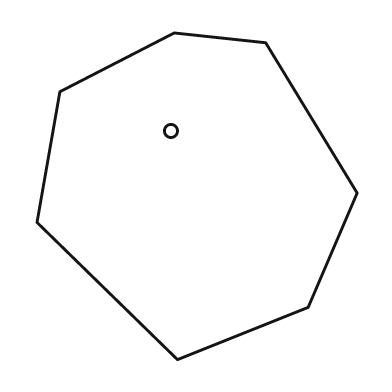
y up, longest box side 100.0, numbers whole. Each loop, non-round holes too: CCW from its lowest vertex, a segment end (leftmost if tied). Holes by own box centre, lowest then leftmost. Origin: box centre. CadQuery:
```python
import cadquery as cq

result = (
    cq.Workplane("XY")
    .moveTo(-6.0, -50.0)
    .lineTo(34.0, -34.0)
    .lineTo(49.0, 1.0)
    .lineTo(21.0, 47.0)
    .lineTo(-7.0, 50.0)
    .lineTo(-42.0, 32.0)
    .lineTo(-49.0, -8.0)
    .close()
    .moveTo(-8.0, 20.0)
    .circle(2.0)
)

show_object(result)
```